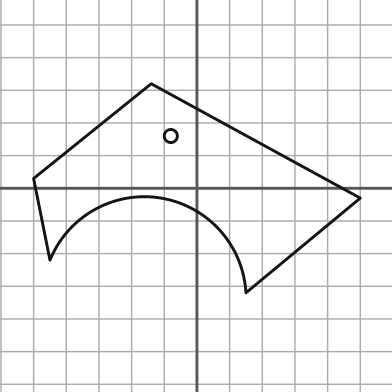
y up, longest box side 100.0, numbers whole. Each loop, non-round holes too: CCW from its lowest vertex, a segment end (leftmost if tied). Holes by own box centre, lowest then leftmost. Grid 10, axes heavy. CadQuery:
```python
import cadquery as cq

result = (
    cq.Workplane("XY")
    .moveTo(15.0, -32.0)
    .lineTo(50.0, -3.0)
    .lineTo(-14.0, 32.0)
    .lineTo(-50.0, 3.0)
    .lineTo(-45.0, -22.0)
    .threePointArc((-11.0, -3.0), (15.0, -32.0))
    .close()
    .moveTo(-8.0, 16.0)
    .circle(2.0)
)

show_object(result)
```